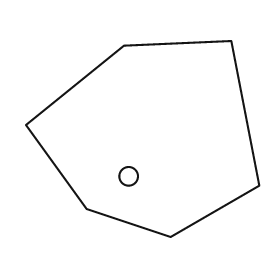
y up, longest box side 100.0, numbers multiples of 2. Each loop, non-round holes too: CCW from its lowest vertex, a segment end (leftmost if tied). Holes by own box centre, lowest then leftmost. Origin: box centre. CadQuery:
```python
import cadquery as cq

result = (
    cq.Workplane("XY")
    .moveTo(12.0, -42.0)
    .lineTo(50.0, -20.0)
    .lineTo(38.0, 42.0)
    .lineTo(-8.0, 40.0)
    .lineTo(-50.0, 6.0)
    .lineTo(-24.0, -30.0)
    .close()
    .moveTo(-6.0, -16.0)
    .circle(4.0)
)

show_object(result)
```